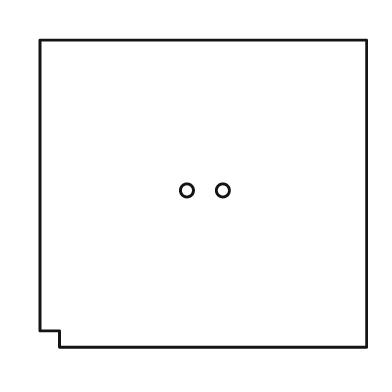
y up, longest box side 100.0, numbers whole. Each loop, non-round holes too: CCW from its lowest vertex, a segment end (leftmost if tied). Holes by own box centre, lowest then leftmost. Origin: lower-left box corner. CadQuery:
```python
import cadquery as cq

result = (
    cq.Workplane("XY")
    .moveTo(6.0, 0.0)
    .lineTo(100.0, 0.0)
    .lineTo(100.0, 94.0)
    .lineTo(0.0, 94.0)
    .lineTo(0.0, 5.0)
    .lineTo(6.0, 5.0)
    .close()
    .moveTo(45.0, 48.0)
    .circle(2.0)
    .moveTo(56.0, 48.0)
    .circle(2.0)
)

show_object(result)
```